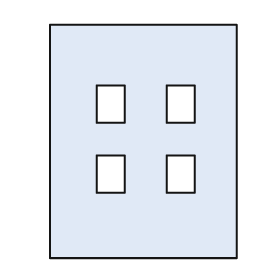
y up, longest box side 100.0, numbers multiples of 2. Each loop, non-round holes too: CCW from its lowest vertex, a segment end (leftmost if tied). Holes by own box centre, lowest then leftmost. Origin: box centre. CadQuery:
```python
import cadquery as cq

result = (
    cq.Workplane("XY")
    .moveTo(-40.0, -50.0)
    .lineTo(40.0, -50.0)
    .lineTo(40.0, 50.0)
    .lineTo(-40.0, 50.0)
    .close()
    .moveTo(-20.0, -22.0)
    .lineTo(-8.0, -22.0)
    .lineTo(-8.0, -6.0)
    .lineTo(-20.0, -6.0)
    .close()
    .moveTo(10.0, -22.0)
    .lineTo(22.0, -22.0)
    .lineTo(22.0, -6.0)
    .lineTo(10.0, -6.0)
    .close()
    .moveTo(-20.0, 8.0)
    .lineTo(-8.0, 8.0)
    .lineTo(-8.0, 24.0)
    .lineTo(-20.0, 24.0)
    .close()
    .moveTo(10.0, 8.0)
    .lineTo(22.0, 8.0)
    .lineTo(22.0, 24.0)
    .lineTo(10.0, 24.0)
    .close()
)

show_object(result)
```